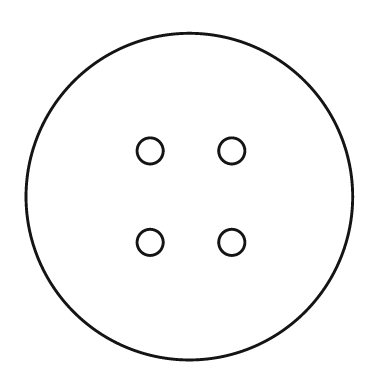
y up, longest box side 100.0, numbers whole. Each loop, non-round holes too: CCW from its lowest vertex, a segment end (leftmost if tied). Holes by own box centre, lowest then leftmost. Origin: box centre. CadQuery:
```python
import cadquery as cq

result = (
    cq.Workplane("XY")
    .moveTo(0.0, 0.0)
    .circle(50.0)
    .moveTo(-12.0, -14.0)
    .circle(4.0)
    .moveTo(13.0, -14.0)
    .circle(4.0)
    .moveTo(-12.0, 14.0)
    .circle(4.0)
    .moveTo(13.0, 14.0)
    .circle(4.0)
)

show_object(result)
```